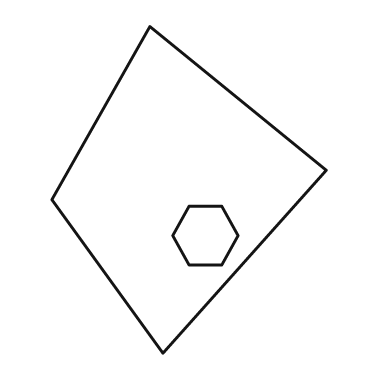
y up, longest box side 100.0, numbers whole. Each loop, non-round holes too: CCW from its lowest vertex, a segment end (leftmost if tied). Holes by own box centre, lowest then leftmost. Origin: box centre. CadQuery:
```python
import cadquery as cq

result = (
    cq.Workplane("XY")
    .moveTo(-8.0, -50.0)
    .lineTo(42.0, 6.0)
    .lineTo(-12.0, 50.0)
    .lineTo(-42.0, -3.0)
    .close()
    .moveTo(0.0, -23.0)
    .lineTo(10.0, -23.0)
    .lineTo(15.0, -14.0)
    .lineTo(10.0, -5.0)
    .lineTo(0.0, -5.0)
    .lineTo(-5.0, -14.0)
    .close()
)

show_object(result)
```